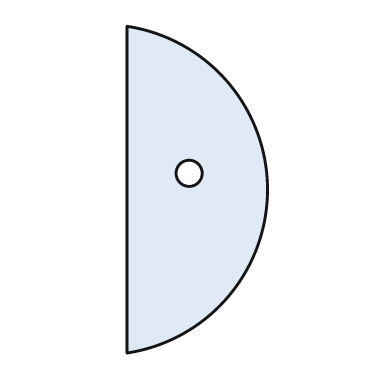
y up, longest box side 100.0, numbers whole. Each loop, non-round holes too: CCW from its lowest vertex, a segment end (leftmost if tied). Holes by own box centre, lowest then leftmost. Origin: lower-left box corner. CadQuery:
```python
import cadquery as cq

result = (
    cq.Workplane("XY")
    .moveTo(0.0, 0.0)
    .threePointArc((43.0, 50.0), (0.0, 100.0))
    .close()
    .moveTo(19.0, 55.0)
    .circle(4.0)
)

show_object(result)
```